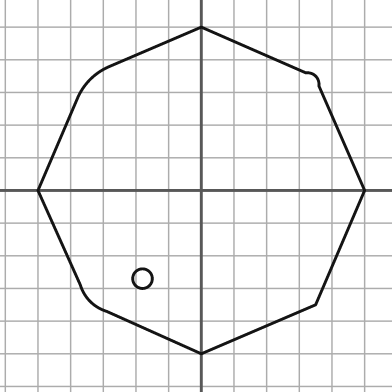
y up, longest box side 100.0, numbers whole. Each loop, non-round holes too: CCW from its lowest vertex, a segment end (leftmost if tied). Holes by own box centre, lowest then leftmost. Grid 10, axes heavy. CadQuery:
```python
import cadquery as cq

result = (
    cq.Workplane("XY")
    .moveTo(0.0, -50.0)
    .lineTo(35.0, -35.0)
    .lineTo(50.0, 0.0)
    .lineTo(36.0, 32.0)
    .threePointArc((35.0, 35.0), (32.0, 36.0))
    .lineTo(0.0, 50.0)
    .lineTo(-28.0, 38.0)
    .threePointArc((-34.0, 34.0), (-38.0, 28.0))
    .lineTo(-50.0, 0.0)
    .lineTo(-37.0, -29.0)
    .threePointArc((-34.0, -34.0), (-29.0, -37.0))
    .close()
    .moveTo(-18.0, -27.0)
    .circle(3.0)
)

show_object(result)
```